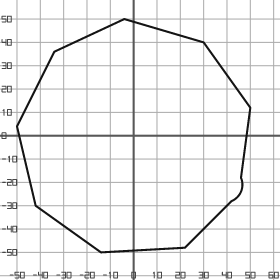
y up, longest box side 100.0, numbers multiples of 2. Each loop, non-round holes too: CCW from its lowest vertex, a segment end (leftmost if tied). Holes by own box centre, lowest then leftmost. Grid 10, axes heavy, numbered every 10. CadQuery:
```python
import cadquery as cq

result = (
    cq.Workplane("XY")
    .moveTo(-14.0, -50.0)
    .lineTo(22.0, -48.0)
    .lineTo(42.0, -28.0)
    .threePointArc((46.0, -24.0), (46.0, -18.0))
    .lineTo(50.0, 12.0)
    .lineTo(30.0, 40.0)
    .lineTo(-4.0, 50.0)
    .lineTo(-34.0, 36.0)
    .lineTo(-50.0, 4.0)
    .lineTo(-42.0, -30.0)
    .close()
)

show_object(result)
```